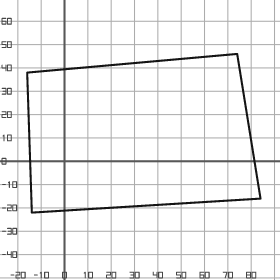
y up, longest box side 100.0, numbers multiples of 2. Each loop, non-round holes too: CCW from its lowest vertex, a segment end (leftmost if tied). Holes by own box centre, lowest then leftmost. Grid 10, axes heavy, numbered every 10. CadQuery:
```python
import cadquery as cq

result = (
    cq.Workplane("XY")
    .moveTo(-14.0, -22.0)
    .lineTo(84.0, -16.0)
    .lineTo(74.0, 46.0)
    .lineTo(-16.0, 38.0)
    .close()
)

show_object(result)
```